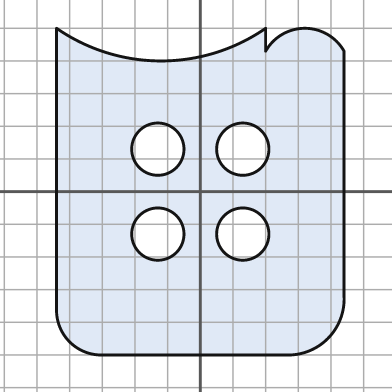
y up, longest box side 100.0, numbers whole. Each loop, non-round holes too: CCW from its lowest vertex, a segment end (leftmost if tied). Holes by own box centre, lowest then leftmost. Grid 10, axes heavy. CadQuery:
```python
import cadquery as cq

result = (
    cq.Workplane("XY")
    .moveTo(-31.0, -50.0)
    .lineTo(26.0, -50.0)
    .threePointArc((39.0, -45.0), (44.0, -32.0))
    .lineTo(44.0, 43.0)
    .threePointArc((32.0, 50.0), (20.0, 43.0))
    .lineTo(20.0, 50.0)
    .threePointArc((-12.0, 40.0), (-44.0, 50.0))
    .lineTo(-44.0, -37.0)
    .threePointArc((-40.0, -46.0), (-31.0, -50.0))
    .close()
    .moveTo(-13.0, -13.0)
    .circle(8.0)
    .moveTo(13.0, -13.0)
    .circle(8.0)
    .moveTo(-13.0, 13.0)
    .circle(8.0)
    .moveTo(13.0, 13.0)
    .circle(8.0)
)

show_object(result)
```